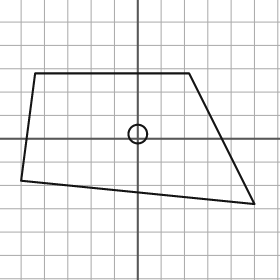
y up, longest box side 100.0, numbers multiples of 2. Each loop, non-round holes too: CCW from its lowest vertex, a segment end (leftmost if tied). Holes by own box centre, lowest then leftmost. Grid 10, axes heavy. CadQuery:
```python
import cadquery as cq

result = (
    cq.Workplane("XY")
    .moveTo(50.0, -28.0)
    .lineTo(22.0, 28.0)
    .lineTo(-44.0, 28.0)
    .lineTo(-50.0, -18.0)
    .close()
    .moveTo(0.0, 2.0)
    .circle(4.0)
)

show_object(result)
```